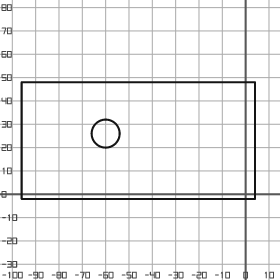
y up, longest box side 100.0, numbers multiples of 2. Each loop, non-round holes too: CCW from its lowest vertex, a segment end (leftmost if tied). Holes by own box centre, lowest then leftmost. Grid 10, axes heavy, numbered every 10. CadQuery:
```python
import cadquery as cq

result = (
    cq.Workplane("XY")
    .moveTo(-96.0, -2.0)
    .lineTo(4.0, -2.0)
    .lineTo(4.0, 48.0)
    .lineTo(-96.0, 48.0)
    .close()
    .moveTo(-60.0, 26.0)
    .circle(6.0)
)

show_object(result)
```